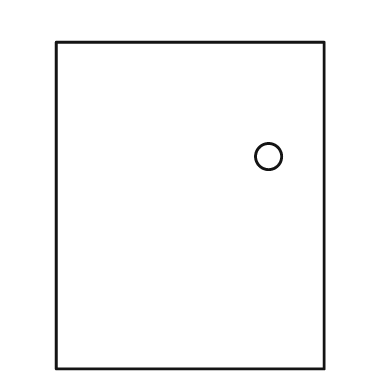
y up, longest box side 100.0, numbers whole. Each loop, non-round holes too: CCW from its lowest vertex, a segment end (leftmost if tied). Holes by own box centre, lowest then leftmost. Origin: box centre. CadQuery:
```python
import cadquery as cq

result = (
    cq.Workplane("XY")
    .moveTo(-41.0, -50.0)
    .lineTo(41.0, -50.0)
    .lineTo(41.0, 50.0)
    .lineTo(-41.0, 50.0)
    .close()
    .moveTo(24.0, 15.0)
    .circle(4.0)
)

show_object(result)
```